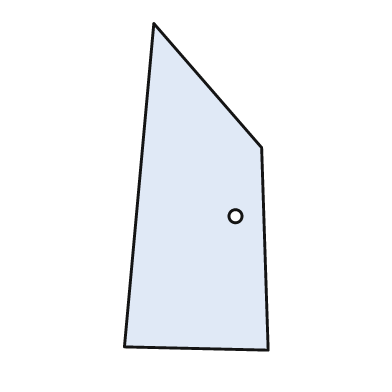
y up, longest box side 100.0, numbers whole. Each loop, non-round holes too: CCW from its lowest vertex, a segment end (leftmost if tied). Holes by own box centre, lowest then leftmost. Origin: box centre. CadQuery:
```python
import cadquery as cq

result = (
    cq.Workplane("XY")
    .moveTo(22.0, -50.0)
    .lineTo(20.0, 12.0)
    .lineTo(-13.0, 50.0)
    .lineTo(-22.0, -49.0)
    .close()
    .moveTo(12.0, -9.0)
    .circle(2.0)
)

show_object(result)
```